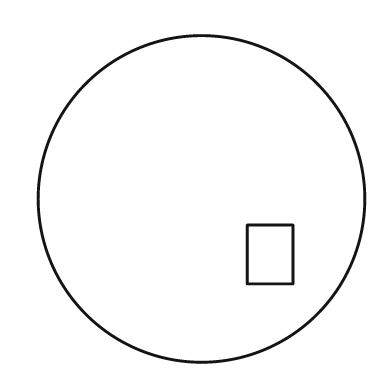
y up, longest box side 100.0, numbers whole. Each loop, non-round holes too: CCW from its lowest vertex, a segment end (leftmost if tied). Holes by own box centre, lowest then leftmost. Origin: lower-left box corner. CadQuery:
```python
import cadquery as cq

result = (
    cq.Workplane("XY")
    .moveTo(50.0, 50.0)
    .circle(50.0)
    .moveTo(64.0, 24.0)
    .lineTo(78.0, 24.0)
    .lineTo(78.0, 42.0)
    .lineTo(64.0, 42.0)
    .close()
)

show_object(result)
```